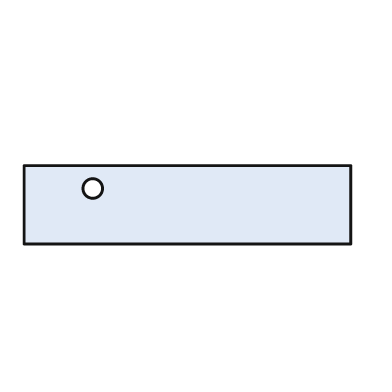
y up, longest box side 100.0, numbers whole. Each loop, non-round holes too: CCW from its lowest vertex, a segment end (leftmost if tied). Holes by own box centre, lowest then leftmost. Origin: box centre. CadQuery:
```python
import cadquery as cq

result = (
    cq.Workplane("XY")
    .moveTo(-50.0, -12.0)
    .lineTo(50.0, -12.0)
    .lineTo(50.0, 12.0)
    .lineTo(-50.0, 12.0)
    .close()
    .moveTo(-29.0, 5.0)
    .circle(3.0)
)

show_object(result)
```